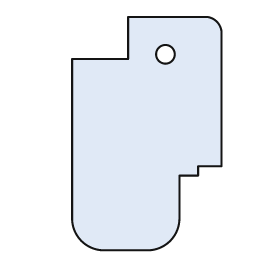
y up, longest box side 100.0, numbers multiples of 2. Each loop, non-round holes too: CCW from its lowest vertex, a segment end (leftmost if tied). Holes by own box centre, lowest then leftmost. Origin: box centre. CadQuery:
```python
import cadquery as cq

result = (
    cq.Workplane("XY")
    .moveTo(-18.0, -50.0)
    .lineTo(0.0, -50.0)
    .threePointArc((10.0, -46.0), (14.0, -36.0))
    .lineTo(14.0, -18.0)
    .lineTo(22.0, -18.0)
    .lineTo(22.0, -14.0)
    .lineTo(32.0, -14.0)
    .lineTo(32.0, 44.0)
    .threePointArc((30.0, 48.0), (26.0, 50.0))
    .lineTo(-8.0, 50.0)
    .lineTo(-8.0, 32.0)
    .lineTo(-32.0, 32.0)
    .lineTo(-32.0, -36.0)
    .threePointArc((-28.0, -46.0), (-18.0, -50.0))
    .close()
    .moveTo(8.0, 34.0)
    .circle(4.0)
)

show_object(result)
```